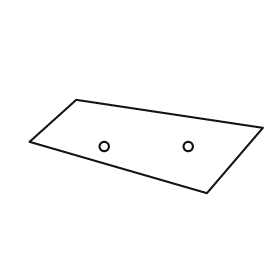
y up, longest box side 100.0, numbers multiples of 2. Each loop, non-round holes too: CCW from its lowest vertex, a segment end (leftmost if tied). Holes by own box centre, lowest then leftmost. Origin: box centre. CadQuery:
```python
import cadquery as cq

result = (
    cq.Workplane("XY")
    .moveTo(26.0, -20.0)
    .lineTo(50.0, 8.0)
    .lineTo(-30.0, 20.0)
    .lineTo(-50.0, 2.0)
    .close()
    .moveTo(-18.0, 0.0)
    .circle(2.0)
    .moveTo(18.0, 0.0)
    .circle(2.0)
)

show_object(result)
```